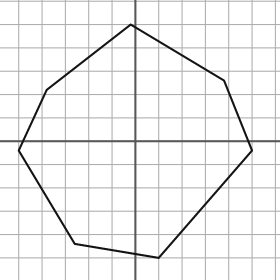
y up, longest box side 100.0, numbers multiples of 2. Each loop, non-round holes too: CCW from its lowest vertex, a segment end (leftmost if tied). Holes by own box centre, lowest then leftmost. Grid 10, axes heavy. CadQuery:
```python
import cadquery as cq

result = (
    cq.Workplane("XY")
    .moveTo(10.0, -50.0)
    .lineTo(50.0, -4.0)
    .lineTo(38.0, 26.0)
    .lineTo(-2.0, 50.0)
    .lineTo(-38.0, 22.0)
    .lineTo(-50.0, -4.0)
    .lineTo(-26.0, -44.0)
    .close()
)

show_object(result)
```